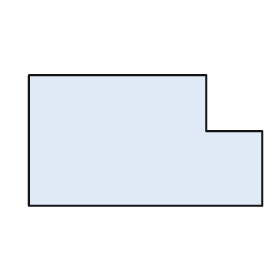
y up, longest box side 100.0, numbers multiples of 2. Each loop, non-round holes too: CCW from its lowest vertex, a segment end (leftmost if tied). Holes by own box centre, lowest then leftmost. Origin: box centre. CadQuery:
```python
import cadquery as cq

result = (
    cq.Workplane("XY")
    .moveTo(-50.0, -28.0)
    .lineTo(50.0, -28.0)
    .lineTo(50.0, 4.0)
    .lineTo(26.0, 4.0)
    .lineTo(26.0, 28.0)
    .lineTo(-50.0, 28.0)
    .close()
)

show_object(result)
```